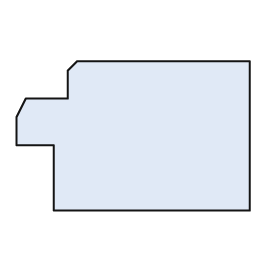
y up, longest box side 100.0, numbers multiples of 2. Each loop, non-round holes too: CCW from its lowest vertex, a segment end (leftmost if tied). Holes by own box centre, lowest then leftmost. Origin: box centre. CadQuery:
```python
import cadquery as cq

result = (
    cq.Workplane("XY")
    .moveTo(-34.0, -32.0)
    .lineTo(50.0, -32.0)
    .lineTo(50.0, 32.0)
    .lineTo(-24.0, 32.0)
    .lineTo(-28.0, 28.0)
    .lineTo(-28.0, 16.0)
    .lineTo(-46.0, 16.0)
    .lineTo(-50.0, 8.0)
    .lineTo(-50.0, -4.0)
    .lineTo(-34.0, -4.0)
    .close()
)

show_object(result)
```